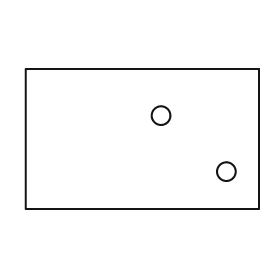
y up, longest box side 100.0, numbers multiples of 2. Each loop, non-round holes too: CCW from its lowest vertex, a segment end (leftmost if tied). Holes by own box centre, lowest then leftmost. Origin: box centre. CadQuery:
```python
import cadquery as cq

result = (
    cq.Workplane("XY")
    .moveTo(-50.0, -30.0)
    .lineTo(50.0, -30.0)
    .lineTo(50.0, 30.0)
    .lineTo(-50.0, 30.0)
    .close()
    .moveTo(36.0, -14.0)
    .circle(4.0)
    .moveTo(8.0, 10.0)
    .circle(4.0)
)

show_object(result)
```